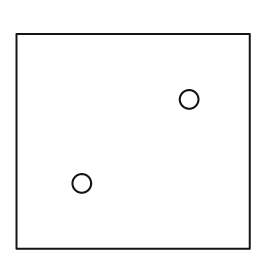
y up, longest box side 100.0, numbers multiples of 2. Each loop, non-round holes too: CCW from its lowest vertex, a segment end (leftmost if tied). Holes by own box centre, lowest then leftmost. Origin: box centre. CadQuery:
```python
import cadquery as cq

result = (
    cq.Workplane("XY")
    .moveTo(-50.0, -46.0)
    .lineTo(50.0, -46.0)
    .lineTo(50.0, 46.0)
    .lineTo(-50.0, 46.0)
    .close()
    .moveTo(-22.0, -18.0)
    .circle(4.0)
    .moveTo(24.0, 18.0)
    .circle(4.0)
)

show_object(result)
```